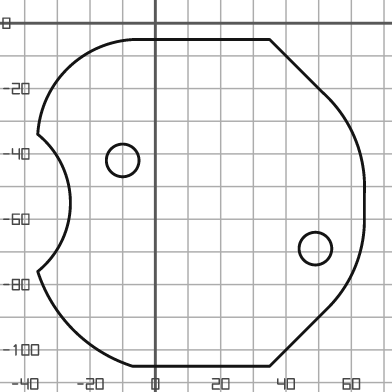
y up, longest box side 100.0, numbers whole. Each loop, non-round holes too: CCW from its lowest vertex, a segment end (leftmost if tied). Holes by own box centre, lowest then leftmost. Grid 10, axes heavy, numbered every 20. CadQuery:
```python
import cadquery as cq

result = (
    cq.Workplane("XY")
    .moveTo(-7.0, -105.0)
    .lineTo(35.0, -105.0)
    .lineTo(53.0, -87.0)
    .threePointArc((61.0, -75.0), (64.0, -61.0))
    .lineTo(64.0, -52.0)
    .threePointArc((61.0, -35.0), (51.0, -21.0))
    .lineTo(35.0, -5.0)
    .lineTo(-7.0, -5.0)
    .threePointArc((-27.0, -14.0), (-36.0, -34.0))
    .threePointArc((-26.0, -55.0), (-36.0, -76.0))
    .threePointArc((-25.0, -94.0), (-7.0, -105.0))
    .close()
    .moveTo(49.0, -69.0)
    .circle(5.0)
    .moveTo(-10.0, -42.0)
    .circle(5.0)
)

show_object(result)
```